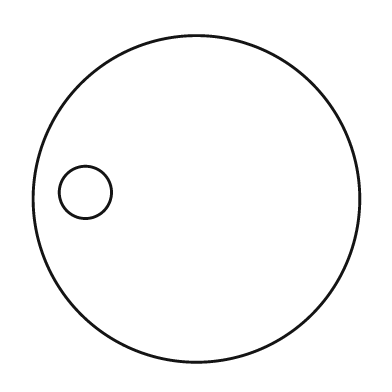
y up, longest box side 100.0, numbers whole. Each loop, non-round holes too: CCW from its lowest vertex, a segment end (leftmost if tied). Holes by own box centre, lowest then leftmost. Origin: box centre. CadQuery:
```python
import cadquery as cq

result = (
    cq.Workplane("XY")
    .moveTo(0.0, 0.0)
    .circle(50.0)
    .moveTo(-34.0, 2.0)
    .circle(8.0)
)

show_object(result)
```